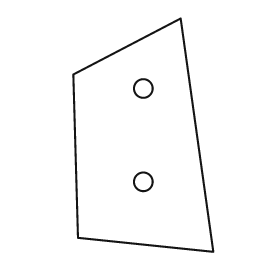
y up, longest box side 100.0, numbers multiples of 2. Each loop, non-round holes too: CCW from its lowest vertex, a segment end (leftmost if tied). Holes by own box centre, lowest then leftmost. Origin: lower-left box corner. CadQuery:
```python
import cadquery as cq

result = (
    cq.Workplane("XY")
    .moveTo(60.0, 0.0)
    .lineTo(46.0, 100.0)
    .lineTo(0.0, 76.0)
    .lineTo(2.0, 6.0)
    .close()
    .moveTo(30.0, 30.0)
    .circle(4.0)
    .moveTo(30.0, 70.0)
    .circle(4.0)
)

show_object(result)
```